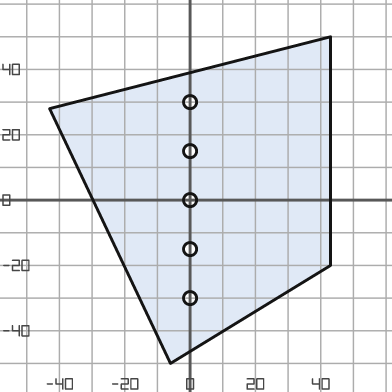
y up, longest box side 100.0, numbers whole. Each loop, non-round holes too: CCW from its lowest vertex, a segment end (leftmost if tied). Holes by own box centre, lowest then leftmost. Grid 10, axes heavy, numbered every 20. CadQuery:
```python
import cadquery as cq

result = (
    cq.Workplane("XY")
    .moveTo(-6.0, -50.0)
    .lineTo(43.0, -20.0)
    .lineTo(43.0, 50.0)
    .lineTo(-43.0, 28.0)
    .close()
    .moveTo(0.0, -30.0)
    .circle(2.0)
    .moveTo(0.0, -15.0)
    .circle(2.0)
    .moveTo(0.0, 0.0)
    .circle(2.0)
    .moveTo(0.0, 15.0)
    .circle(2.0)
    .moveTo(0.0, 30.0)
    .circle(2.0)
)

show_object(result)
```